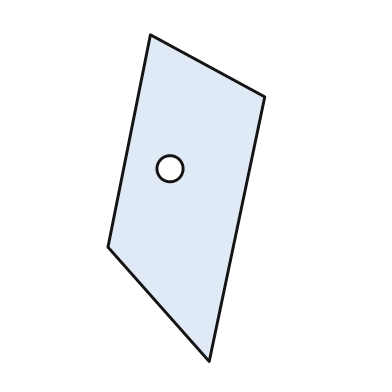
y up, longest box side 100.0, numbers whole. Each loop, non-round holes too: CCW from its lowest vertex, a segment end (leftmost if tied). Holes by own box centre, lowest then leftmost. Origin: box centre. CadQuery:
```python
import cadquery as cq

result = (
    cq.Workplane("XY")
    .moveTo(7.0, -50.0)
    .lineTo(24.0, 31.0)
    .lineTo(-11.0, 50.0)
    .lineTo(-24.0, -15.0)
    .close()
    .moveTo(-5.0, 9.0)
    .circle(4.0)
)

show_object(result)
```